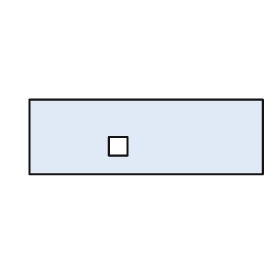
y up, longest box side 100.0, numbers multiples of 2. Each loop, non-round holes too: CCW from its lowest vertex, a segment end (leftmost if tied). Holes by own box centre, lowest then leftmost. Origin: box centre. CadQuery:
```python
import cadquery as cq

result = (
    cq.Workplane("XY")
    .moveTo(-50.0, -16.0)
    .lineTo(50.0, -16.0)
    .lineTo(50.0, 16.0)
    .lineTo(-50.0, 16.0)
    .close()
    .moveTo(-16.0, -8.0)
    .lineTo(-8.0, -8.0)
    .lineTo(-8.0, 0.0)
    .lineTo(-16.0, 0.0)
    .close()
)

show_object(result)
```